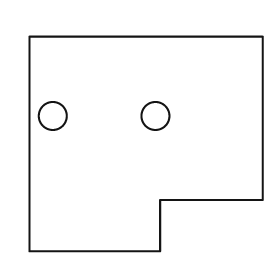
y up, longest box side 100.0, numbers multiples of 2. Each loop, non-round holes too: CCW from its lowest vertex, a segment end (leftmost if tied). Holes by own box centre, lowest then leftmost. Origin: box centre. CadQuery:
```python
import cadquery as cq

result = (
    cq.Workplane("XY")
    .moveTo(-50.0, -46.0)
    .lineTo(6.0, -46.0)
    .lineTo(6.0, -24.0)
    .lineTo(50.0, -24.0)
    .lineTo(50.0, 46.0)
    .lineTo(-50.0, 46.0)
    .close()
    .moveTo(-40.0, 12.0)
    .circle(6.0)
    .moveTo(4.0, 12.0)
    .circle(6.0)
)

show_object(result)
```